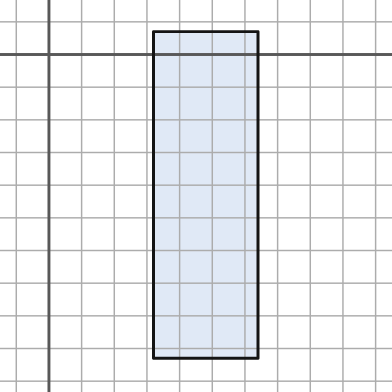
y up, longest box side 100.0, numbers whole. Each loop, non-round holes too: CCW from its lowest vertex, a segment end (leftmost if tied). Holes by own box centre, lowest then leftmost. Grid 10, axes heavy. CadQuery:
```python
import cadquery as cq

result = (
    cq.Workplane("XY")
    .moveTo(32.0, -93.0)
    .lineTo(64.0, -93.0)
    .lineTo(64.0, 7.0)
    .lineTo(32.0, 7.0)
    .close()
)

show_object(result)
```